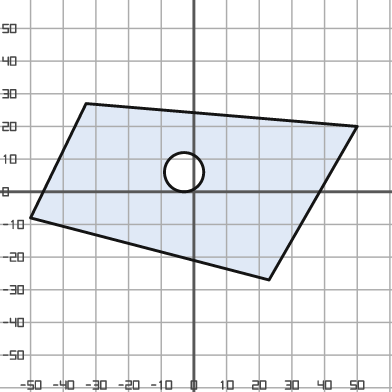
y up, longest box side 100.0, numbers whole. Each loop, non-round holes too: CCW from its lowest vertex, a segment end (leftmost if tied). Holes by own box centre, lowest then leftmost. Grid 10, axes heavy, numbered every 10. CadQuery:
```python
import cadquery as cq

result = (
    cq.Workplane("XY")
    .moveTo(23.0, -27.0)
    .lineTo(50.0, 20.0)
    .lineTo(-33.0, 27.0)
    .lineTo(-50.0, -8.0)
    .close()
    .moveTo(-3.0, 6.0)
    .circle(6.0)
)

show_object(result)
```